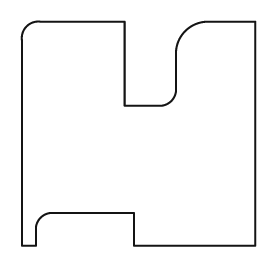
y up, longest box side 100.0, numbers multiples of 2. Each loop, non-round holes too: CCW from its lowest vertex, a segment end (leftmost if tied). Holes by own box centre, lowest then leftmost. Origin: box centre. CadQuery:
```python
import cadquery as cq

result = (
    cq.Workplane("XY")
    .moveTo(-50.0, -48.0)
    .lineTo(-44.0, -48.0)
    .lineTo(-44.0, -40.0)
    .threePointArc((-42.0, -36.0), (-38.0, -34.0))
    .lineTo(-2.0, -34.0)
    .lineTo(-2.0, -48.0)
    .lineTo(50.0, -48.0)
    .lineTo(50.0, 48.0)
    .lineTo(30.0, 48.0)
    .threePointArc((20.0, 44.0), (16.0, 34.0))
    .lineTo(16.0, 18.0)
    .threePointArc((14.0, 14.0), (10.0, 12.0))
    .lineTo(-6.0, 12.0)
    .lineTo(-6.0, 48.0)
    .lineTo(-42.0, 48.0)
    .threePointArc((-48.0, 46.0), (-50.0, 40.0))
    .close()
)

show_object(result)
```